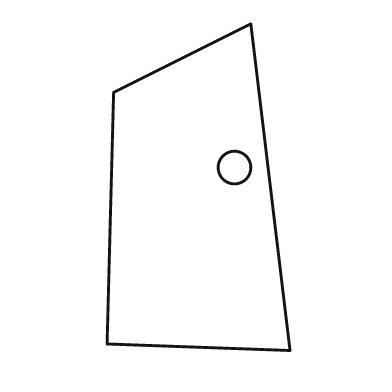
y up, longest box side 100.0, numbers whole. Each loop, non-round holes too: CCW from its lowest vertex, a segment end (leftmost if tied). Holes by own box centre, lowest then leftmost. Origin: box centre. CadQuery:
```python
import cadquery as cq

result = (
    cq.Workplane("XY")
    .moveTo(28.0, -50.0)
    .lineTo(16.0, 50.0)
    .lineTo(-26.0, 29.0)
    .lineTo(-28.0, -48.0)
    .close()
    .moveTo(11.0, 6.0)
    .circle(5.0)
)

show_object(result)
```